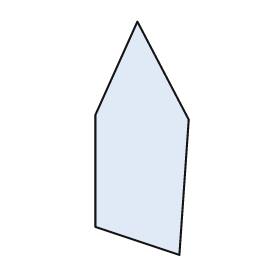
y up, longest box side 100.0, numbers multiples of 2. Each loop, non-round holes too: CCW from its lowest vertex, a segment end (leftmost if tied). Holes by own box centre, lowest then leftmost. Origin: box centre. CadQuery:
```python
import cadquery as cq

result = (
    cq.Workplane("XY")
    .moveTo(16.0, -50.0)
    .lineTo(20.0, 8.0)
    .lineTo(-2.0, 50.0)
    .lineTo(-20.0, 10.0)
    .lineTo(-20.0, -38.0)
    .close()
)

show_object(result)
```